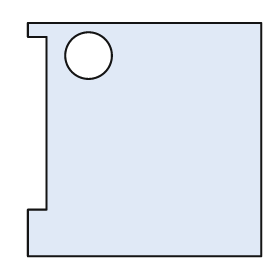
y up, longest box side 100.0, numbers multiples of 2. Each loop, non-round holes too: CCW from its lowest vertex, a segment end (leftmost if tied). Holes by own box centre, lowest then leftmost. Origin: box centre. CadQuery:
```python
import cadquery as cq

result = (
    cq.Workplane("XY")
    .moveTo(-50.0, -50.0)
    .lineTo(50.0, -50.0)
    .lineTo(50.0, 50.0)
    .lineTo(-50.0, 50.0)
    .lineTo(-50.0, 44.0)
    .lineTo(-42.0, 44.0)
    .lineTo(-42.0, -30.0)
    .lineTo(-50.0, -30.0)
    .close()
    .moveTo(-24.0, 36.0)
    .circle(10.0)
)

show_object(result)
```